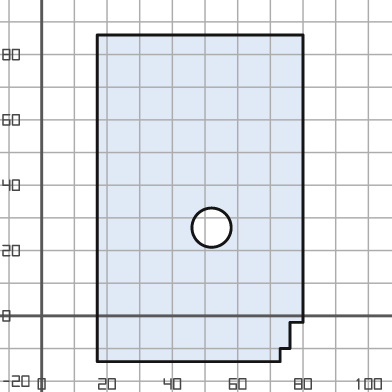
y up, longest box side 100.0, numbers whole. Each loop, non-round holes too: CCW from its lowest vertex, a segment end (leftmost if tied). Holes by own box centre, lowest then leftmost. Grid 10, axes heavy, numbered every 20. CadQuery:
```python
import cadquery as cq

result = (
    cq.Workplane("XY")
    .moveTo(17.0, -14.0)
    .lineTo(73.0, -14.0)
    .lineTo(73.0, -10.0)
    .lineTo(76.0, -10.0)
    .lineTo(76.0, -2.0)
    .lineTo(80.0, -2.0)
    .lineTo(80.0, 86.0)
    .lineTo(17.0, 86.0)
    .close()
    .moveTo(52.0, 27.0)
    .circle(6.0)
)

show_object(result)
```